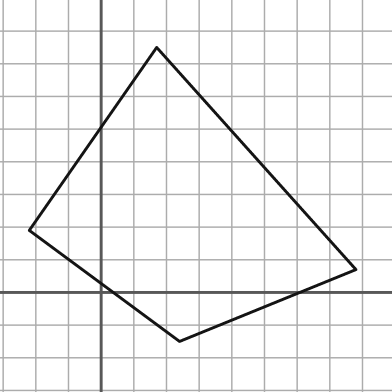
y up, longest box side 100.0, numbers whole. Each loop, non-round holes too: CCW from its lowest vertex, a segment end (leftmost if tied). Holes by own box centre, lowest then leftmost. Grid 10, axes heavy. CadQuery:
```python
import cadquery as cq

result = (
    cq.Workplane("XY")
    .moveTo(24.0, -15.0)
    .lineTo(78.0, 7.0)
    .lineTo(17.0, 75.0)
    .lineTo(-22.0, 19.0)
    .close()
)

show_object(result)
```